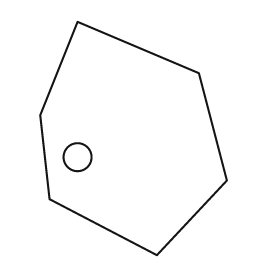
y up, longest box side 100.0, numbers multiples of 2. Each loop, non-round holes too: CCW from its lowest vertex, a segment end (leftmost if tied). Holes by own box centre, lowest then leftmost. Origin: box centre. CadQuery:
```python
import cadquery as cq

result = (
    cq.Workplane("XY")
    .moveTo(10.0, -50.0)
    .lineTo(40.0, -18.0)
    .lineTo(28.0, 28.0)
    .lineTo(-24.0, 50.0)
    .lineTo(-40.0, 10.0)
    .lineTo(-36.0, -26.0)
    .close()
    .moveTo(-24.0, -8.0)
    .circle(6.0)
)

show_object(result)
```